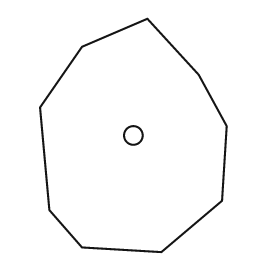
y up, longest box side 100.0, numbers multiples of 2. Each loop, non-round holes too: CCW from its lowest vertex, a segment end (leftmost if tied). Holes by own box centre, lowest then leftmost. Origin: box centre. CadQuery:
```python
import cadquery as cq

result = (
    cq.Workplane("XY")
    .moveTo(12.0, -50.0)
    .lineTo(38.0, -28.0)
    .lineTo(40.0, 4.0)
    .lineTo(28.0, 26.0)
    .lineTo(6.0, 50.0)
    .lineTo(-22.0, 38.0)
    .lineTo(-40.0, 12.0)
    .lineTo(-36.0, -32.0)
    .lineTo(-22.0, -48.0)
    .close()
    .moveTo(0.0, 0.0)
    .circle(4.0)
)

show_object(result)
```